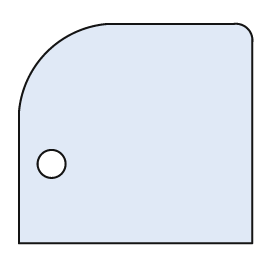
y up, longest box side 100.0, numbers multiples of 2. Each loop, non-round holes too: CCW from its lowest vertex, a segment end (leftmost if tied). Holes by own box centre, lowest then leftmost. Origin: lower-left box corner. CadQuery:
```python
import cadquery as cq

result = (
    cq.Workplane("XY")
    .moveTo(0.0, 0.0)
    .lineTo(100.0, 0.0)
    .lineTo(100.0, 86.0)
    .threePointArc((98.0, 92.0), (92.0, 94.0))
    .lineTo(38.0, 94.0)
    .threePointArc((12.0, 82.0), (0.0, 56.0))
    .close()
    .moveTo(14.0, 34.0)
    .circle(6.0)
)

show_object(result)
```